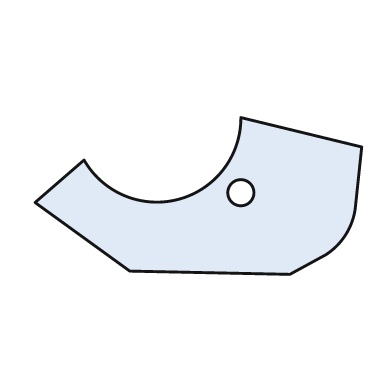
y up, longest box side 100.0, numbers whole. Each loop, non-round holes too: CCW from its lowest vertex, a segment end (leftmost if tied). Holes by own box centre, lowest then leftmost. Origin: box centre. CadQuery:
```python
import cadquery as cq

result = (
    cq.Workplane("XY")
    .moveTo(28.0, -24.0)
    .lineTo(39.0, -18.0)
    .threePointArc((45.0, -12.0), (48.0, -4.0))
    .lineTo(50.0, 15.0)
    .lineTo(13.0, 24.0)
    .threePointArc((-6.0, -1.0), (-35.0, 11.0))
    .lineTo(-50.0, -2.0)
    .lineTo(-21.0, -23.0)
    .close()
    .moveTo(13.0, 1.0)
    .circle(4.0)
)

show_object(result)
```